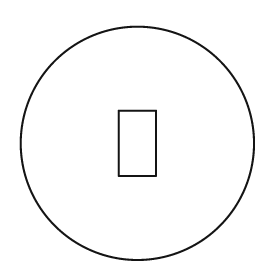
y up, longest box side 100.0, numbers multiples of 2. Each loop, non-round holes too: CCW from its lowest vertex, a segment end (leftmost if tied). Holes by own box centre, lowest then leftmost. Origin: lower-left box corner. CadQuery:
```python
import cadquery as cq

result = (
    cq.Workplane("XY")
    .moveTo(50.0, 50.0)
    .circle(50.0)
    .moveTo(42.0, 36.0)
    .lineTo(58.0, 36.0)
    .lineTo(58.0, 64.0)
    .lineTo(42.0, 64.0)
    .close()
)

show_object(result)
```